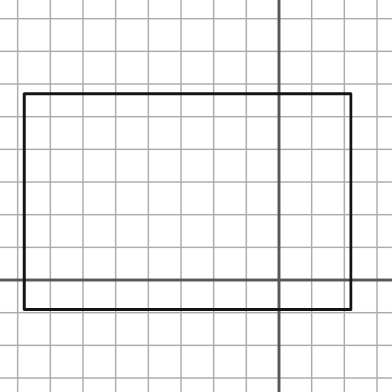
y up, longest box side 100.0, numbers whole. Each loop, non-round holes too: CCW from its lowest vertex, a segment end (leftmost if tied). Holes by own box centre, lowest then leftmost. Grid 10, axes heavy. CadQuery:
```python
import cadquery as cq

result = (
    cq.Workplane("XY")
    .moveTo(-78.0, -9.0)
    .lineTo(22.0, -9.0)
    .lineTo(22.0, 57.0)
    .lineTo(-78.0, 57.0)
    .close()
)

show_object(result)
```